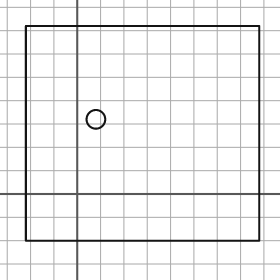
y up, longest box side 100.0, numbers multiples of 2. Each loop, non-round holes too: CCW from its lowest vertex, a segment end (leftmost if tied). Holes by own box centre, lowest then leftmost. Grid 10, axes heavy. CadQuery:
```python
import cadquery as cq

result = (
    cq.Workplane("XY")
    .moveTo(-22.0, -20.0)
    .lineTo(78.0, -20.0)
    .lineTo(78.0, 72.0)
    .lineTo(-22.0, 72.0)
    .close()
    .moveTo(8.0, 32.0)
    .circle(4.0)
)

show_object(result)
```